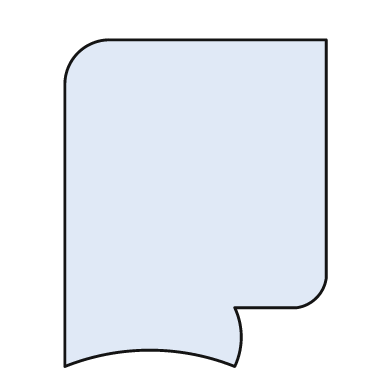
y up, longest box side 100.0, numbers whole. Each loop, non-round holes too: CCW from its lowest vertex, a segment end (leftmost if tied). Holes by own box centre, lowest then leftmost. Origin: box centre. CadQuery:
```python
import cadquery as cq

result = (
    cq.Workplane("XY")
    .moveTo(-40.0, -50.0)
    .threePointArc((-14.0, -45.0), (12.0, -50.0))
    .threePointArc((14.0, -41.0), (12.0, -32.0))
    .lineTo(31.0, -32.0)
    .threePointArc((37.0, -29.0), (40.0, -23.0))
    .lineTo(40.0, 50.0)
    .lineTo(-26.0, 50.0)
    .threePointArc((-36.0, 46.0), (-40.0, 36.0))
    .close()
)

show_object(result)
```